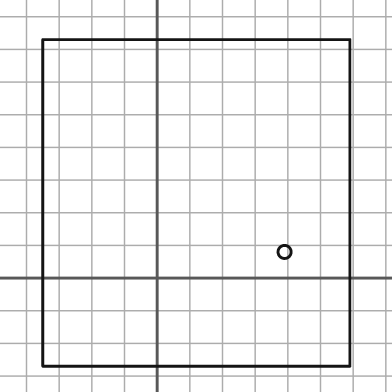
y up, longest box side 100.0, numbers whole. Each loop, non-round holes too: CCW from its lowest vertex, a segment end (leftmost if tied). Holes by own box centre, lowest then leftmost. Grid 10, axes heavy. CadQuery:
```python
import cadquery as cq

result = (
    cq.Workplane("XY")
    .moveTo(-35.0, -27.0)
    .lineTo(59.0, -27.0)
    .lineTo(59.0, 73.0)
    .lineTo(-35.0, 73.0)
    .close()
    .moveTo(39.0, 8.0)
    .circle(2.0)
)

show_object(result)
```